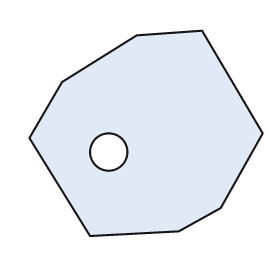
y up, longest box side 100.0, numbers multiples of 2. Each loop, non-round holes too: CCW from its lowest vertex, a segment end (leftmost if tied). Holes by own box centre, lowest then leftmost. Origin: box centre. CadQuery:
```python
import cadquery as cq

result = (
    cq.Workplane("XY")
    .moveTo(-24.0, -44.0)
    .lineTo(14.0, -42.0)
    .lineTo(32.0, -32.0)
    .lineTo(50.0, 0.0)
    .lineTo(24.0, 44.0)
    .lineTo(-4.0, 42.0)
    .lineTo(-36.0, 22.0)
    .lineTo(-50.0, -2.0)
    .close()
    .moveTo(-16.0, -8.0)
    .circle(8.0)
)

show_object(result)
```